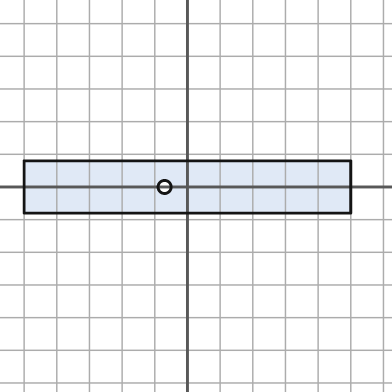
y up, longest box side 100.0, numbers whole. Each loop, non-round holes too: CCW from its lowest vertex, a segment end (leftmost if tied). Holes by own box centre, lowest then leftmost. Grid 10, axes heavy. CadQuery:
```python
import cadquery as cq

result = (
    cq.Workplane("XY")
    .moveTo(-50.0, -8.0)
    .lineTo(50.0, -8.0)
    .lineTo(50.0, 8.0)
    .lineTo(-50.0, 8.0)
    .close()
    .moveTo(-7.0, 0.0)
    .circle(2.0)
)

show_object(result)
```